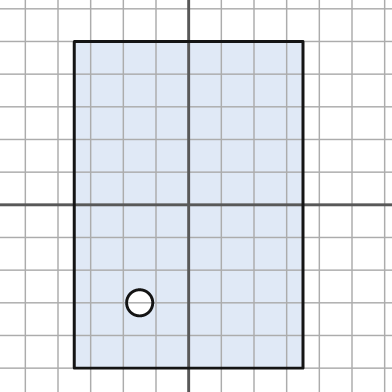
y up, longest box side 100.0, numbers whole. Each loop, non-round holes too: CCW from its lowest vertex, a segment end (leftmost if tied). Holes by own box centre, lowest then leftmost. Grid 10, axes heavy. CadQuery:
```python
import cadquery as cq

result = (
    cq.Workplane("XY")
    .moveTo(-35.0, -50.0)
    .lineTo(35.0, -50.0)
    .lineTo(35.0, 50.0)
    .lineTo(-35.0, 50.0)
    .close()
    .moveTo(-15.0, -30.0)
    .circle(4.0)
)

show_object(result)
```